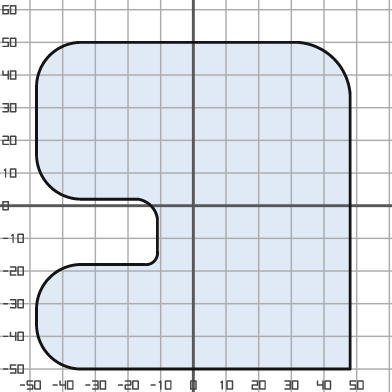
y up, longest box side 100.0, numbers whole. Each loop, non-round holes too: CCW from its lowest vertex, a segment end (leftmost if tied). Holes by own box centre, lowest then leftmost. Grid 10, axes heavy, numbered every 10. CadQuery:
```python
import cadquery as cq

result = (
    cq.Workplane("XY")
    .moveTo(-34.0, -50.0)
    .lineTo(48.0, -50.0)
    .lineTo(48.0, 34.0)
    .threePointArc((43.0, 45.0), (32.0, 50.0))
    .lineTo(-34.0, 50.0)
    .threePointArc((-44.0, 46.0), (-48.0, 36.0))
    .lineTo(-48.0, 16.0)
    .threePointArc((-44.0, 6.0), (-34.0, 2.0))
    .lineTo(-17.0, 2.0)
    .threePointArc((-13.0, 0.0), (-11.0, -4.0))
    .lineTo(-11.0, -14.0)
    .threePointArc((-12.0, -17.0), (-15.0, -18.0))
    .lineTo(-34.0, -18.0)
    .threePointArc((-44.0, -22.0), (-48.0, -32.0))
    .lineTo(-48.0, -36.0)
    .threePointArc((-44.0, -46.0), (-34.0, -50.0))
    .close()
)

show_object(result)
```